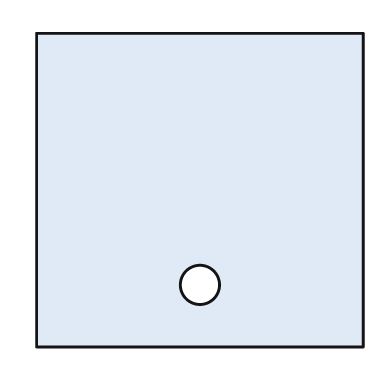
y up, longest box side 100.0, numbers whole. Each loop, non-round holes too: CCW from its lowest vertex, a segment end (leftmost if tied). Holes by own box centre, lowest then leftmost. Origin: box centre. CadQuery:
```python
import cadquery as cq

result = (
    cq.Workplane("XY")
    .moveTo(-50.0, -48.0)
    .lineTo(50.0, -48.0)
    .lineTo(50.0, 48.0)
    .lineTo(-50.0, 48.0)
    .close()
    .moveTo(0.0, -29.0)
    .circle(6.0)
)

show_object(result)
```